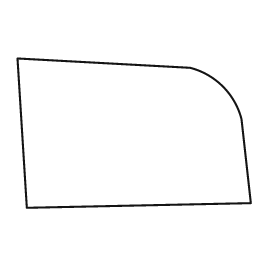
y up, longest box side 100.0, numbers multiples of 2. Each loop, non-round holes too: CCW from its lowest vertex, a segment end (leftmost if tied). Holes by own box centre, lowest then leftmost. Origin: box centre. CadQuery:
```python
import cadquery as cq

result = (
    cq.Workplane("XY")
    .moveTo(-46.0, -32.0)
    .lineTo(50.0, -30.0)
    .lineTo(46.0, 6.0)
    .threePointArc((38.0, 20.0), (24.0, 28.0))
    .lineTo(-50.0, 32.0)
    .close()
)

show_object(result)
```